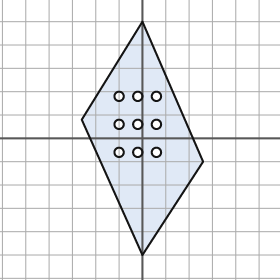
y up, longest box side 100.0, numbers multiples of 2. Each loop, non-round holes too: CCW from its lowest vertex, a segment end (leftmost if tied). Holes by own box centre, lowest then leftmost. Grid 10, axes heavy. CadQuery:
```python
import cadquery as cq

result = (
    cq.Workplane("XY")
    .moveTo(0.0, -50.0)
    .lineTo(26.0, -10.0)
    .lineTo(0.0, 50.0)
    .lineTo(-26.0, 8.0)
    .close()
    .moveTo(-10.0, -6.0)
    .circle(2.0)
    .moveTo(-2.0, -6.0)
    .circle(2.0)
    .moveTo(6.0, -6.0)
    .circle(2.0)
    .moveTo(-10.0, 6.0)
    .circle(2.0)
    .moveTo(-2.0, 6.0)
    .circle(2.0)
    .moveTo(6.0, 6.0)
    .circle(2.0)
    .moveTo(-10.0, 18.0)
    .circle(2.0)
    .moveTo(-2.0, 18.0)
    .circle(2.0)
    .moveTo(6.0, 18.0)
    .circle(2.0)
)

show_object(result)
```